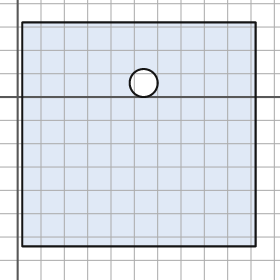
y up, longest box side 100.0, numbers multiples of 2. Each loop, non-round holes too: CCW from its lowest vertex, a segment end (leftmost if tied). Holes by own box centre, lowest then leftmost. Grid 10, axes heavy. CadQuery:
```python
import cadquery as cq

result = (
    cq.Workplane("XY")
    .moveTo(2.0, -64.0)
    .lineTo(102.0, -64.0)
    .lineTo(102.0, 32.0)
    .lineTo(2.0, 32.0)
    .close()
    .moveTo(54.0, 6.0)
    .circle(6.0)
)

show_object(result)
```